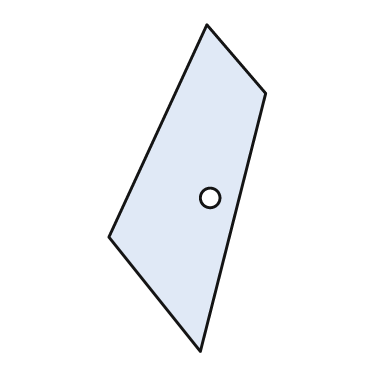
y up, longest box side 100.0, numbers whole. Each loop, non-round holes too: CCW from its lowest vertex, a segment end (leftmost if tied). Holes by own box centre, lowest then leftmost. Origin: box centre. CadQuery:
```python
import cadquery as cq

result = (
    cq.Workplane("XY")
    .moveTo(4.0, -50.0)
    .lineTo(24.0, 29.0)
    .lineTo(6.0, 50.0)
    .lineTo(-24.0, -15.0)
    .close()
    .moveTo(7.0, -3.0)
    .circle(3.0)
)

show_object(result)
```